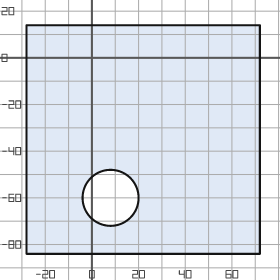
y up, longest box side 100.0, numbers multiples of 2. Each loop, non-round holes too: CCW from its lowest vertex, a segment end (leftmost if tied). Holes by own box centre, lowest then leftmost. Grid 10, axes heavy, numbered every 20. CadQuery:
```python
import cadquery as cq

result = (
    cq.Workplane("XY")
    .moveTo(-28.0, -84.0)
    .lineTo(72.0, -84.0)
    .lineTo(72.0, 14.0)
    .lineTo(-28.0, 14.0)
    .close()
    .moveTo(8.0, -60.0)
    .circle(12.0)
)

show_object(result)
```